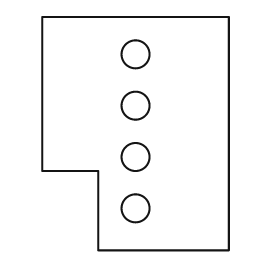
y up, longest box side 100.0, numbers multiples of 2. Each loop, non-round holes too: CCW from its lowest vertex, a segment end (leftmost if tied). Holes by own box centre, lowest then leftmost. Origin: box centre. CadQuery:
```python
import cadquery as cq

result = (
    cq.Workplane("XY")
    .moveTo(-16.0, -50.0)
    .lineTo(40.0, -50.0)
    .lineTo(40.0, 50.0)
    .lineTo(-40.0, 50.0)
    .lineTo(-40.0, -16.0)
    .lineTo(-16.0, -16.0)
    .close()
    .moveTo(0.0, -32.0)
    .circle(6.0)
    .moveTo(0.0, -10.0)
    .circle(6.0)
    .moveTo(0.0, 12.0)
    .circle(6.0)
    .moveTo(0.0, 34.0)
    .circle(6.0)
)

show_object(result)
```